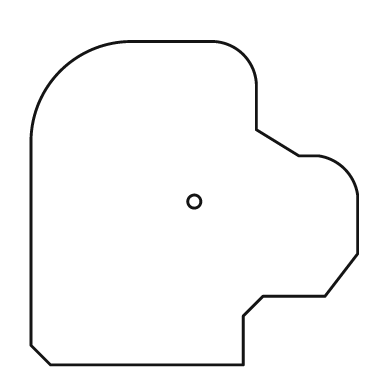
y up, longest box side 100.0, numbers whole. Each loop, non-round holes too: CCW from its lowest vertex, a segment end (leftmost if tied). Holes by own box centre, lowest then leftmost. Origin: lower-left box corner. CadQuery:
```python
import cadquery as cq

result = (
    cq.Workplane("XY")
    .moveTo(6.0, 0.0)
    .lineTo(65.0, 0.0)
    .lineTo(65.0, 15.0)
    .lineTo(71.0, 21.0)
    .lineTo(90.0, 21.0)
    .lineTo(100.0, 34.0)
    .lineTo(100.0, 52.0)
    .threePointArc((96.0, 60.0), (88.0, 64.0))
    .lineTo(82.0, 64.0)
    .lineTo(69.0, 72.0)
    .lineTo(69.0, 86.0)
    .threePointArc((65.0, 95.0), (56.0, 99.0))
    .lineTo(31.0, 99.0)
    .threePointArc((9.0, 90.0), (0.0, 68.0))
    .lineTo(0.0, 6.0)
    .close()
    .moveTo(50.0, 50.0)
    .circle(2.0)
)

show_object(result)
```